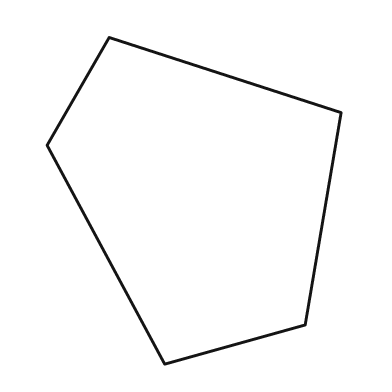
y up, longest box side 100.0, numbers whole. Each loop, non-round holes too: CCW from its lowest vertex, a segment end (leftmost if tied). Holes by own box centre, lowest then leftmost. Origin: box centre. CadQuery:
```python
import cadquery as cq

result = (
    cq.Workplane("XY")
    .moveTo(-9.0, -50.0)
    .lineTo(34.0, -38.0)
    .lineTo(45.0, 27.0)
    .lineTo(-26.0, 50.0)
    .lineTo(-45.0, 17.0)
    .close()
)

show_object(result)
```